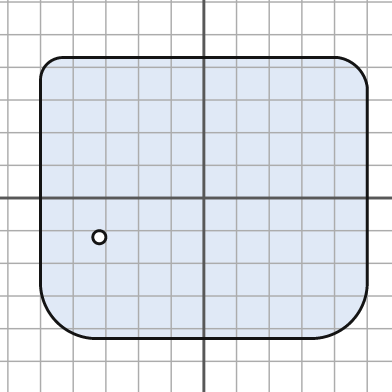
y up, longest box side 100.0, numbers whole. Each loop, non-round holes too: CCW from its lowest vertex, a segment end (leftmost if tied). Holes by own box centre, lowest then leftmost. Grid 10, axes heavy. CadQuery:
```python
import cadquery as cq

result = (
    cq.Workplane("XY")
    .moveTo(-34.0, -43.0)
    .lineTo(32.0, -43.0)
    .threePointArc((45.0, -38.0), (50.0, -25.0))
    .lineTo(50.0, 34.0)
    .threePointArc((47.0, 40.0), (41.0, 43.0))
    .lineTo(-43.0, 43.0)
    .threePointArc((-48.0, 41.0), (-50.0, 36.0))
    .lineTo(-50.0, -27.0)
    .threePointArc((-45.0, -38.0), (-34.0, -43.0))
    .close()
    .moveTo(-32.0, -12.0)
    .circle(2.0)
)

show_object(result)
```